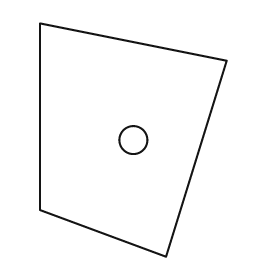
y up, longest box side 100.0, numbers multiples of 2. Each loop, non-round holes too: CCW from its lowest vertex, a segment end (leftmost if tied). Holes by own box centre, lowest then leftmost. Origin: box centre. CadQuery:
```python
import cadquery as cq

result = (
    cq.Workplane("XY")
    .moveTo(14.0, -50.0)
    .lineTo(40.0, 34.0)
    .lineTo(-40.0, 50.0)
    .lineTo(-40.0, -30.0)
    .close()
    .moveTo(0.0, 0.0)
    .circle(6.0)
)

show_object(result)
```